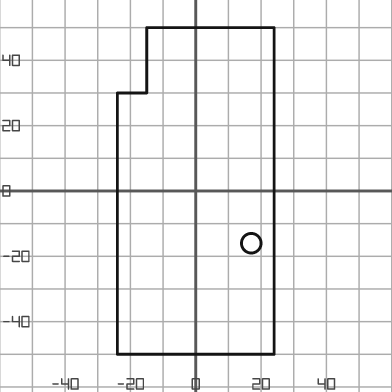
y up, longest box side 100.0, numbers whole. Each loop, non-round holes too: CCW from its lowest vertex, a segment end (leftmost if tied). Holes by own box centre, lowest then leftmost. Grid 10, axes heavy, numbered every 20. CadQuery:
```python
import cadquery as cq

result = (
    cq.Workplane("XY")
    .moveTo(-24.0, -50.0)
    .lineTo(24.0, -50.0)
    .lineTo(24.0, 50.0)
    .lineTo(-15.0, 50.0)
    .lineTo(-15.0, 30.0)
    .lineTo(-24.0, 30.0)
    .close()
    .moveTo(17.0, -16.0)
    .circle(3.0)
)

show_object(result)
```